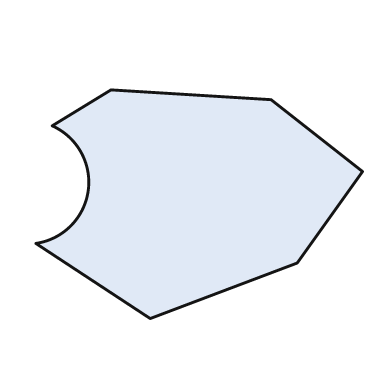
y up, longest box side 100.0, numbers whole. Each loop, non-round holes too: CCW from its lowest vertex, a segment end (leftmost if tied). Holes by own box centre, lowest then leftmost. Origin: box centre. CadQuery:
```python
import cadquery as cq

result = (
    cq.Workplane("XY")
    .moveTo(-15.0, -35.0)
    .lineTo(30.0, -18.0)
    .lineTo(50.0, 10.0)
    .lineTo(22.0, 32.0)
    .lineTo(-27.0, 35.0)
    .lineTo(-45.0, 24.0)
    .threePointArc((-34.0, 4.0), (-50.0, -12.0))
    .close()
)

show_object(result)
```